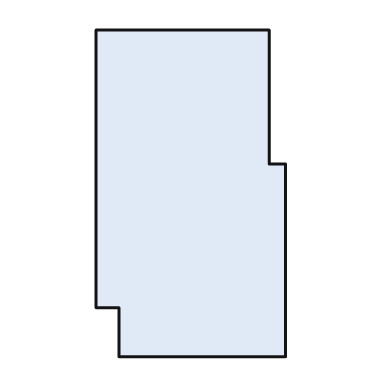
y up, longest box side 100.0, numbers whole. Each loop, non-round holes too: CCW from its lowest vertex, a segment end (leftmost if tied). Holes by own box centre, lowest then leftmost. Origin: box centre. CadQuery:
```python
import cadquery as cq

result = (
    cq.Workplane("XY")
    .moveTo(-22.0, -50.0)
    .lineTo(29.0, -50.0)
    .lineTo(29.0, 9.0)
    .lineTo(24.0, 9.0)
    .lineTo(24.0, 50.0)
    .lineTo(-29.0, 50.0)
    .lineTo(-29.0, -35.0)
    .lineTo(-22.0, -35.0)
    .close()
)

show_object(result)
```